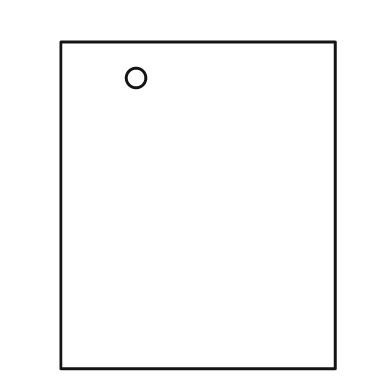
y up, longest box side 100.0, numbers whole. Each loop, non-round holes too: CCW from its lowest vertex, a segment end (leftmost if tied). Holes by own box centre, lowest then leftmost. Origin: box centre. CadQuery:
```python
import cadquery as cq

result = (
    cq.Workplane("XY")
    .moveTo(-42.0, -50.0)
    .lineTo(42.0, -50.0)
    .lineTo(42.0, 50.0)
    .lineTo(-42.0, 50.0)
    .close()
    .moveTo(-19.0, 39.0)
    .circle(3.0)
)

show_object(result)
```